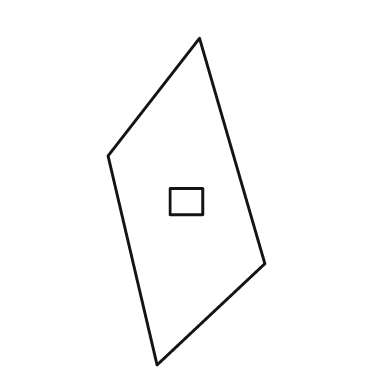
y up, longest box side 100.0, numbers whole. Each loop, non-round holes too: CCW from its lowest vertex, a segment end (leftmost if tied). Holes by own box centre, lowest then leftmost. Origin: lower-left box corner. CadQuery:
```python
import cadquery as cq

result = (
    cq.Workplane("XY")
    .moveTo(15.0, 0.0)
    .lineTo(48.0, 31.0)
    .lineTo(28.0, 100.0)
    .lineTo(0.0, 64.0)
    .close()
    .moveTo(19.0, 46.0)
    .lineTo(29.0, 46.0)
    .lineTo(29.0, 54.0)
    .lineTo(19.0, 54.0)
    .close()
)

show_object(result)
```